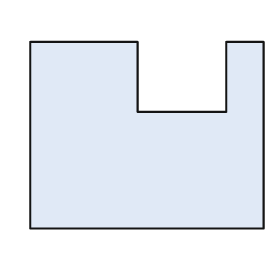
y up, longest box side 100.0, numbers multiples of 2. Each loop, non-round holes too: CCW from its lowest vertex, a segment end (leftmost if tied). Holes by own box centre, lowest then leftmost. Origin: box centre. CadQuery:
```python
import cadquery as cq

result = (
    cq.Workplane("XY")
    .moveTo(-50.0, -40.0)
    .lineTo(50.0, -40.0)
    .lineTo(50.0, 40.0)
    .lineTo(34.0, 40.0)
    .lineTo(34.0, 10.0)
    .lineTo(-4.0, 10.0)
    .lineTo(-4.0, 40.0)
    .lineTo(-50.0, 40.0)
    .close()
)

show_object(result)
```